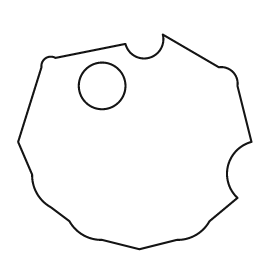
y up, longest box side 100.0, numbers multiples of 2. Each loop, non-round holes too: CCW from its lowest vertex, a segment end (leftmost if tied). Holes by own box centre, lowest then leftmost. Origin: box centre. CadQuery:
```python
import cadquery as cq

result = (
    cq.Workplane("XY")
    .moveTo(2.0, -46.0)
    .lineTo(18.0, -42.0)
    .threePointArc((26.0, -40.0), (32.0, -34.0))
    .lineTo(44.0, -24.0)
    .threePointArc((40.0, -10.0), (50.0, 0.0))
    .lineTo(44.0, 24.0)
    .threePointArc((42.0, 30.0), (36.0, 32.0))
    .lineTo(12.0, 46.0)
    .threePointArc((6.0, 36.0), (-4.0, 42.0))
    .lineTo(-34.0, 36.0)
    .threePointArc((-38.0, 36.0), (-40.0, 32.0))
    .lineTo(-50.0, 0.0)
    .lineTo(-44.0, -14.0)
    .threePointArc((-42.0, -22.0), (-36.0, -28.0))
    .lineTo(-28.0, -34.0)
    .threePointArc((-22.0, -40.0), (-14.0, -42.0))
    .close()
    .moveTo(-14.0, 24.0)
    .circle(10.0)
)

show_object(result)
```